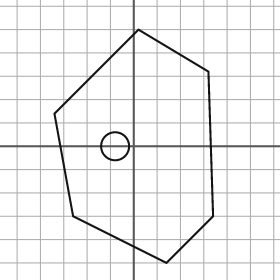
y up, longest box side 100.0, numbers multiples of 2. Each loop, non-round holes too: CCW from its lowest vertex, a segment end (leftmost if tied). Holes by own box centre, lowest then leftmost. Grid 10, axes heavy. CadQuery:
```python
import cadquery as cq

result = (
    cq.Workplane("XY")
    .moveTo(14.0, -50.0)
    .lineTo(34.0, -30.0)
    .lineTo(32.0, 32.0)
    .lineTo(2.0, 50.0)
    .lineTo(-34.0, 14.0)
    .lineTo(-26.0, -30.0)
    .close()
    .moveTo(-8.0, 0.0)
    .circle(6.0)
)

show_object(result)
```